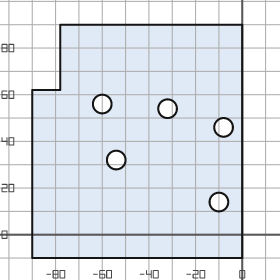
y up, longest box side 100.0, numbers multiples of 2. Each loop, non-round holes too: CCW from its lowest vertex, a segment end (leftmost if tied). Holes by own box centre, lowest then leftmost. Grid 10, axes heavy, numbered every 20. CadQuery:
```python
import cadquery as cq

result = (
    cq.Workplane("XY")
    .moveTo(-90.0, -10.0)
    .lineTo(0.0, -10.0)
    .lineTo(0.0, 90.0)
    .lineTo(-78.0, 90.0)
    .lineTo(-78.0, 62.0)
    .lineTo(-90.0, 62.0)
    .close()
    .moveTo(-10.0, 14.0)
    .circle(4.0)
    .moveTo(-54.0, 32.0)
    .circle(4.0)
    .moveTo(-8.0, 46.0)
    .circle(4.0)
    .moveTo(-32.0, 54.0)
    .circle(4.0)
    .moveTo(-60.0, 56.0)
    .circle(4.0)
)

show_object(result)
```